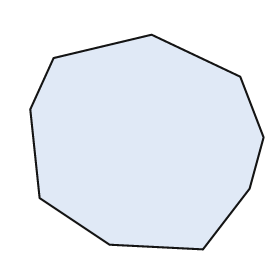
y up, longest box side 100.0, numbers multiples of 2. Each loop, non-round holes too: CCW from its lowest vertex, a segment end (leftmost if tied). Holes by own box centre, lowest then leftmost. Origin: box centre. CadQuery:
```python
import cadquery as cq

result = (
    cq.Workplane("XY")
    .moveTo(24.0, -46.0)
    .lineTo(44.0, -20.0)
    .lineTo(50.0, 2.0)
    .lineTo(40.0, 28.0)
    .lineTo(2.0, 46.0)
    .lineTo(-40.0, 36.0)
    .lineTo(-50.0, 14.0)
    .lineTo(-46.0, -24.0)
    .lineTo(-16.0, -44.0)
    .close()
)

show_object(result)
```